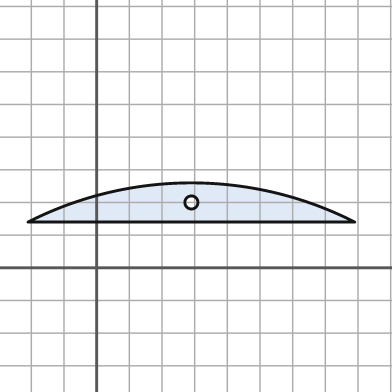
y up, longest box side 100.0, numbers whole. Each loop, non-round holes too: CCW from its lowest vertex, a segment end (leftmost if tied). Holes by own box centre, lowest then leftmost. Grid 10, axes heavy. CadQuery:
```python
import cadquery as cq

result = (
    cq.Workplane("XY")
    .moveTo(-21.0, 14.0)
    .lineTo(79.0, 14.0)
    .threePointArc((29.0, 26.0), (-21.0, 14.0))
    .close()
    .moveTo(29.0, 20.0)
    .circle(2.0)
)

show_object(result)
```